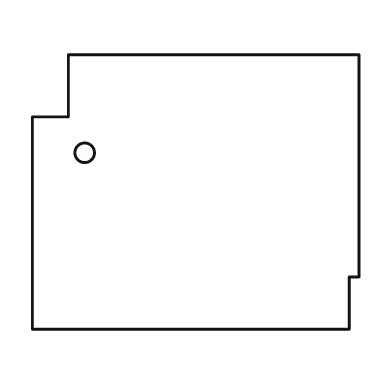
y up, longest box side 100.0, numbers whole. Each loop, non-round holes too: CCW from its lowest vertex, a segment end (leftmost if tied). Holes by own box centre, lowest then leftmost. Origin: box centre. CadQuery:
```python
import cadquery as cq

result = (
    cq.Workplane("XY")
    .moveTo(-50.0, -42.0)
    .lineTo(47.0, -42.0)
    .lineTo(47.0, -26.0)
    .lineTo(50.0, -26.0)
    .lineTo(50.0, 42.0)
    .lineTo(-39.0, 42.0)
    .lineTo(-39.0, 23.0)
    .lineTo(-50.0, 23.0)
    .close()
    .moveTo(-34.0, 12.0)
    .circle(3.0)
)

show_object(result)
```